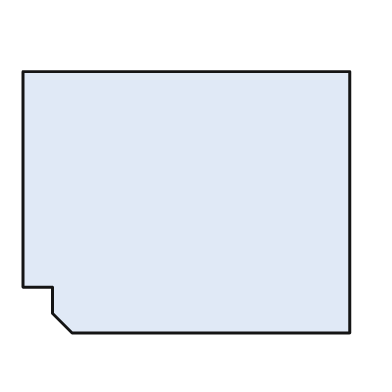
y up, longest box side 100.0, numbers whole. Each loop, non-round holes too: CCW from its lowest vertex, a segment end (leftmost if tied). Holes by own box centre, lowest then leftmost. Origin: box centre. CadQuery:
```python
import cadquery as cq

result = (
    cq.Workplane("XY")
    .moveTo(-35.0, -40.0)
    .lineTo(50.0, -40.0)
    .lineTo(50.0, 40.0)
    .lineTo(-50.0, 40.0)
    .lineTo(-50.0, -26.0)
    .lineTo(-41.0, -26.0)
    .lineTo(-41.0, -34.0)
    .close()
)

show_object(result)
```